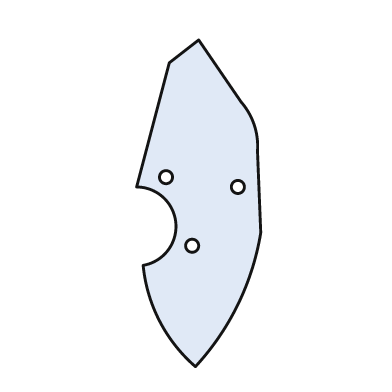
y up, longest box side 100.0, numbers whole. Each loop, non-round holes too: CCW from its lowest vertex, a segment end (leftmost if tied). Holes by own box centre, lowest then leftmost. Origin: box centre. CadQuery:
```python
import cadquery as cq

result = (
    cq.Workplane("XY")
    .moveTo(-1.0, -50.0)
    .threePointArc((12.0, -31.0), (19.0, -9.0))
    .lineTo(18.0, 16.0)
    .threePointArc((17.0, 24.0), (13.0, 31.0))
    .lineTo(0.0, 50.0)
    .lineTo(-9.0, 43.0)
    .lineTo(-19.0, 5.0)
    .threePointArc((-7.0, -6.0), (-17.0, -19.0))
    .threePointArc((-12.0, -36.0), (-1.0, -50.0))
    .close()
    .moveTo(-2.0, -13.0)
    .circle(2.0)
    .moveTo(12.0, 5.0)
    .circle(2.0)
    .moveTo(-10.0, 8.0)
    .circle(2.0)
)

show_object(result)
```